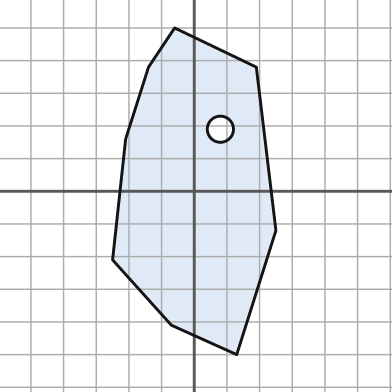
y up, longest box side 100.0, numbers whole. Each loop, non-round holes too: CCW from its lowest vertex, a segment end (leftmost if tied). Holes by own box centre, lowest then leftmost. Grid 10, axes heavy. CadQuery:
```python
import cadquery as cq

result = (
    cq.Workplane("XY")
    .moveTo(13.0, -50.0)
    .lineTo(25.0, -12.0)
    .lineTo(19.0, 38.0)
    .lineTo(-6.0, 50.0)
    .lineTo(-14.0, 38.0)
    .lineTo(-21.0, 16.0)
    .lineTo(-25.0, -21.0)
    .lineTo(-7.0, -41.0)
    .close()
    .moveTo(8.0, 19.0)
    .circle(4.0)
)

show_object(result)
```